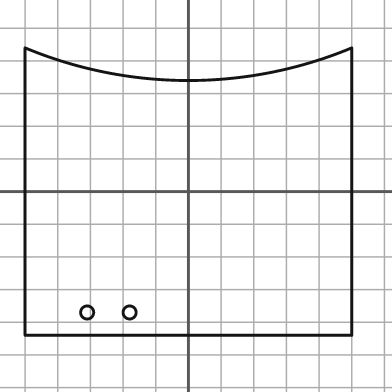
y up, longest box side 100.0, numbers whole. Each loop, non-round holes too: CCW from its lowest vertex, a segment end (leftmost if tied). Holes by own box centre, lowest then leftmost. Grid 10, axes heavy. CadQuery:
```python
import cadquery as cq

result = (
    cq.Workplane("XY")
    .moveTo(-50.0, -44.0)
    .lineTo(50.0, -44.0)
    .lineTo(50.0, 44.0)
    .threePointArc((0.0, 34.0), (-50.0, 44.0))
    .close()
    .moveTo(-31.0, -37.0)
    .circle(2.0)
    .moveTo(-18.0, -37.0)
    .circle(2.0)
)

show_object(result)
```